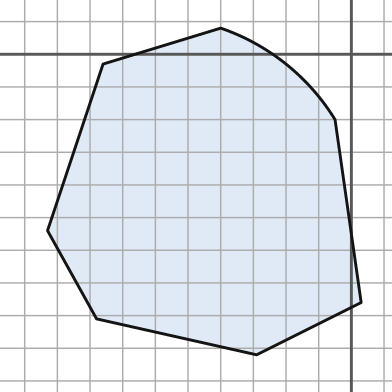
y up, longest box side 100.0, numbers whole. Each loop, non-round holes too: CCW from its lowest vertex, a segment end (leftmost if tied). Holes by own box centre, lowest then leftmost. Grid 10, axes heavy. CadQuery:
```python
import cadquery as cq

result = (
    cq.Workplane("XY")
    .moveTo(-29.0, -92.0)
    .lineTo(3.0, -76.0)
    .lineTo(-5.0, -20.0)
    .threePointArc((-20.0, -3.0), (-40.0, 8.0))
    .lineTo(-76.0, -3.0)
    .lineTo(-93.0, -54.0)
    .lineTo(-78.0, -81.0)
    .close()
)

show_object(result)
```